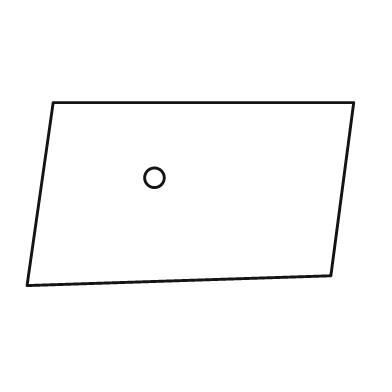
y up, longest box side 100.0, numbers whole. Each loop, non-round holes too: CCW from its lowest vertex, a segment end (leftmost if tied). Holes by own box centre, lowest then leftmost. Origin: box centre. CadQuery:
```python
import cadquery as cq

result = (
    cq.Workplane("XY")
    .moveTo(-50.0, -28.0)
    .lineTo(43.0, -25.0)
    .lineTo(50.0, 28.0)
    .lineTo(-42.0, 28.0)
    .close()
    .moveTo(-11.0, 5.0)
    .circle(3.0)
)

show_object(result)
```